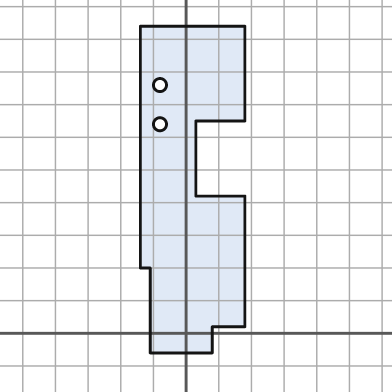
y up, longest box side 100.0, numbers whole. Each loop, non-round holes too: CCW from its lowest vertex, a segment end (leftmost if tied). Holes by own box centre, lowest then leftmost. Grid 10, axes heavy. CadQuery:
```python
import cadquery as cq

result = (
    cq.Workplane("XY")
    .moveTo(-11.0, -6.0)
    .lineTo(8.0, -6.0)
    .lineTo(8.0, 2.0)
    .lineTo(18.0, 2.0)
    .lineTo(18.0, 42.0)
    .lineTo(3.0, 42.0)
    .lineTo(3.0, 65.0)
    .lineTo(18.0, 65.0)
    .lineTo(18.0, 94.0)
    .lineTo(-14.0, 94.0)
    .lineTo(-14.0, 20.0)
    .lineTo(-11.0, 20.0)
    .close()
    .moveTo(-8.0, 64.0)
    .circle(2.0)
    .moveTo(-8.0, 76.0)
    .circle(2.0)
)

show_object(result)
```